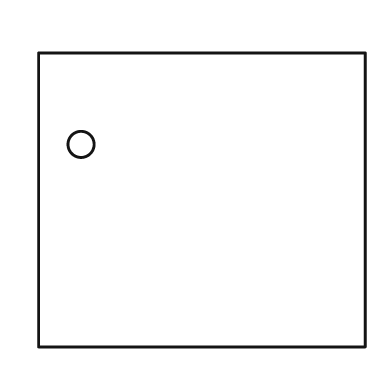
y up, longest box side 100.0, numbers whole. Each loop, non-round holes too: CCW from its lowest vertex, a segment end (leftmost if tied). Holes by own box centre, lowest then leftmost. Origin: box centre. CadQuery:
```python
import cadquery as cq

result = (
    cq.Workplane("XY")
    .moveTo(-50.0, -45.0)
    .lineTo(50.0, -45.0)
    .lineTo(50.0, 45.0)
    .lineTo(-50.0, 45.0)
    .close()
    .moveTo(-37.0, 17.0)
    .circle(4.0)
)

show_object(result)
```